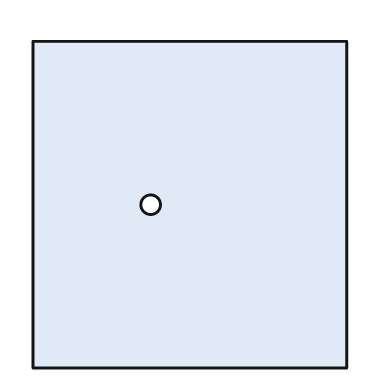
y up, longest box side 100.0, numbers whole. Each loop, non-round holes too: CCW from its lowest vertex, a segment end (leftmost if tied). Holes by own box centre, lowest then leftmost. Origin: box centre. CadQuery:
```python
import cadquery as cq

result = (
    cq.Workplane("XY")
    .moveTo(-48.0, -50.0)
    .lineTo(48.0, -50.0)
    .lineTo(48.0, 50.0)
    .lineTo(-48.0, 50.0)
    .close()
    .moveTo(-12.0, 0.0)
    .circle(3.0)
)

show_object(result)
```